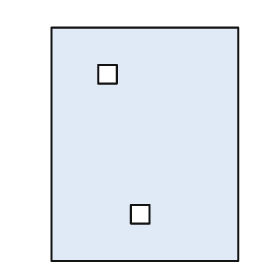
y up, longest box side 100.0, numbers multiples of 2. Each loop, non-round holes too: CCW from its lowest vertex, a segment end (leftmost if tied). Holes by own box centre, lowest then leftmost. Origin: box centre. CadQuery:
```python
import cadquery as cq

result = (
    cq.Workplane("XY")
    .moveTo(-40.0, -50.0)
    .lineTo(40.0, -50.0)
    .lineTo(40.0, 50.0)
    .lineTo(-40.0, 50.0)
    .close()
    .moveTo(-6.0, -34.0)
    .lineTo(2.0, -34.0)
    .lineTo(2.0, -26.0)
    .lineTo(-6.0, -26.0)
    .close()
    .moveTo(-20.0, 26.0)
    .lineTo(-12.0, 26.0)
    .lineTo(-12.0, 34.0)
    .lineTo(-20.0, 34.0)
    .close()
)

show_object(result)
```